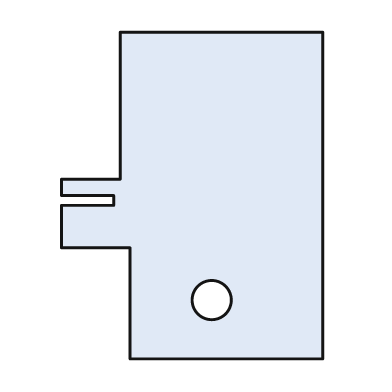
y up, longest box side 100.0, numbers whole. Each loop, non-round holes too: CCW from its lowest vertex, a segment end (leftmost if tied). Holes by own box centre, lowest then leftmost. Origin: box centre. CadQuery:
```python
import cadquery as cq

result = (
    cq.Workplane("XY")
    .moveTo(-19.0, -50.0)
    .lineTo(40.0, -50.0)
    .lineTo(40.0, 50.0)
    .lineTo(-22.0, 50.0)
    .lineTo(-22.0, 5.0)
    .lineTo(-40.0, 5.0)
    .lineTo(-40.0, 0.0)
    .lineTo(-24.0, 0.0)
    .lineTo(-24.0, -3.0)
    .lineTo(-40.0, -3.0)
    .lineTo(-40.0, -16.0)
    .lineTo(-19.0, -16.0)
    .close()
    .moveTo(6.0, -32.0)
    .circle(6.0)
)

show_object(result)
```